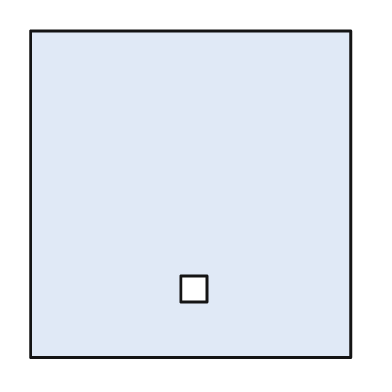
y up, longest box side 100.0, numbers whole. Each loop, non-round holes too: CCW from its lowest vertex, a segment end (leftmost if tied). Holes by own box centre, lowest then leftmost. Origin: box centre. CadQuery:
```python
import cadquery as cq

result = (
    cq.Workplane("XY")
    .moveTo(-49.0, -50.0)
    .lineTo(49.0, -50.0)
    .lineTo(49.0, 50.0)
    .lineTo(-49.0, 50.0)
    .close()
    .moveTo(-3.0, -33.0)
    .lineTo(5.0, -33.0)
    .lineTo(5.0, -25.0)
    .lineTo(-3.0, -25.0)
    .close()
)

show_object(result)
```